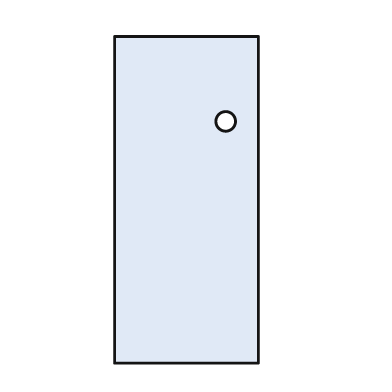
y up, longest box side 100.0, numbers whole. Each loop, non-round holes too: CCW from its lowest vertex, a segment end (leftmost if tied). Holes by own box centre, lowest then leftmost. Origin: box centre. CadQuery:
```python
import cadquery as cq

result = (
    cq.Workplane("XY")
    .moveTo(-22.0, -50.0)
    .lineTo(22.0, -50.0)
    .lineTo(22.0, 50.0)
    .lineTo(-22.0, 50.0)
    .close()
    .moveTo(12.0, 24.0)
    .circle(3.0)
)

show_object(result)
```